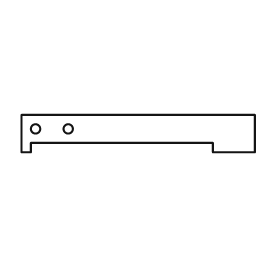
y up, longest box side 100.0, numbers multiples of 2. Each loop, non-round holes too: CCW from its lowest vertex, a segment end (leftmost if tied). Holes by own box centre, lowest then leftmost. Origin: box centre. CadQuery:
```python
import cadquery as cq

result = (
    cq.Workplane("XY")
    .moveTo(-50.0, -8.0)
    .lineTo(-46.0, -8.0)
    .lineTo(-46.0, -4.0)
    .lineTo(32.0, -4.0)
    .lineTo(32.0, -8.0)
    .lineTo(50.0, -8.0)
    .lineTo(50.0, 8.0)
    .lineTo(-50.0, 8.0)
    .close()
    .moveTo(-44.0, 2.0)
    .circle(2.0)
    .moveTo(-30.0, 2.0)
    .circle(2.0)
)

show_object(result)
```